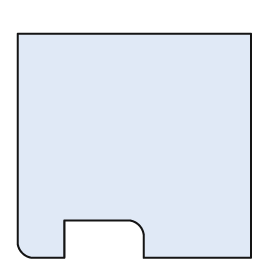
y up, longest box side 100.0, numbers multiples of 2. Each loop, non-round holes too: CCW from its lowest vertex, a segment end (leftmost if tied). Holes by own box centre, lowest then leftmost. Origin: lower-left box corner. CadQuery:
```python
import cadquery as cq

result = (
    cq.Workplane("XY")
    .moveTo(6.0, 0.0)
    .lineTo(20.0, 0.0)
    .lineTo(20.0, 16.0)
    .lineTo(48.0, 16.0)
    .threePointArc((52.0, 14.0), (54.0, 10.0))
    .lineTo(54.0, 0.0)
    .lineTo(100.0, 0.0)
    .lineTo(100.0, 96.0)
    .lineTo(0.0, 96.0)
    .lineTo(0.0, 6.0)
    .threePointArc((2.0, 2.0), (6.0, 0.0))
    .close()
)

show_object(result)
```